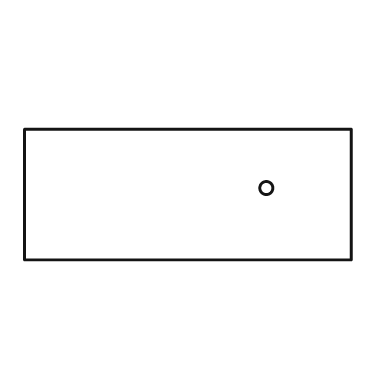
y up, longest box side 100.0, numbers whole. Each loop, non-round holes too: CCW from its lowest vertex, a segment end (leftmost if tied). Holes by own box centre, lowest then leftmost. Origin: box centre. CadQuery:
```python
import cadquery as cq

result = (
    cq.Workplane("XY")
    .moveTo(-50.0, -20.0)
    .lineTo(50.0, -20.0)
    .lineTo(50.0, 20.0)
    .lineTo(-50.0, 20.0)
    .close()
    .moveTo(24.0, 2.0)
    .circle(2.0)
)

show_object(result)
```